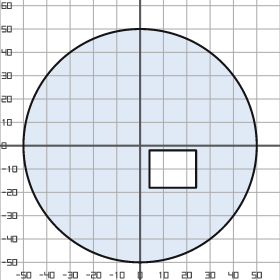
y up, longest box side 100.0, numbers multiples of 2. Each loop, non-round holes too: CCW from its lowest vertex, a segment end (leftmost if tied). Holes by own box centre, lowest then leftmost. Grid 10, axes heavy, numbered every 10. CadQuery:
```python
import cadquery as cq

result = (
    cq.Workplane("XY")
    .moveTo(0.0, 0.0)
    .circle(50.0)
    .moveTo(4.0, -18.0)
    .lineTo(24.0, -18.0)
    .lineTo(24.0, -2.0)
    .lineTo(4.0, -2.0)
    .close()
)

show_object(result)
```